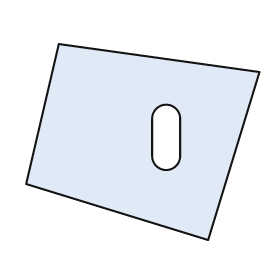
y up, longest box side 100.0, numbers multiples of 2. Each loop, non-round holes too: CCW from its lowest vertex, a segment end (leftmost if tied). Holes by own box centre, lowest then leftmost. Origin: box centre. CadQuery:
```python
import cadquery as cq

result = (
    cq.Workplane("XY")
    .moveTo(28.0, -42.0)
    .lineTo(50.0, 30.0)
    .lineTo(-36.0, 42.0)
    .lineTo(-50.0, -18.0)
    .close()
    .moveTo(4.0, -6.0)
    .threePointArc((10.0, -12.0), (16.0, -6.0))
    .lineTo(16.0, 10.0)
    .threePointArc((10.0, 16.0), (4.0, 10.0))
    .close()
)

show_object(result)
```